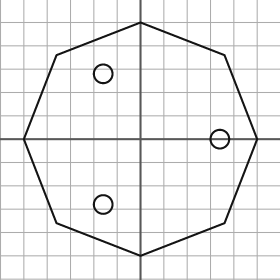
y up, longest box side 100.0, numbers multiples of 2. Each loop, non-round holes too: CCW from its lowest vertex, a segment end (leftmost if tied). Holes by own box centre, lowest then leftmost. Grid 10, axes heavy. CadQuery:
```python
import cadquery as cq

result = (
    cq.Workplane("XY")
    .moveTo(0.0, -50.0)
    .lineTo(36.0, -36.0)
    .lineTo(50.0, 0.0)
    .lineTo(36.0, 36.0)
    .lineTo(0.0, 50.0)
    .lineTo(-36.0, 36.0)
    .lineTo(-50.0, 0.0)
    .lineTo(-36.0, -36.0)
    .close()
    .moveTo(-16.0, -28.0)
    .circle(4.0)
    .moveTo(34.0, 0.0)
    .circle(4.0)
    .moveTo(-16.0, 28.0)
    .circle(4.0)
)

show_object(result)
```